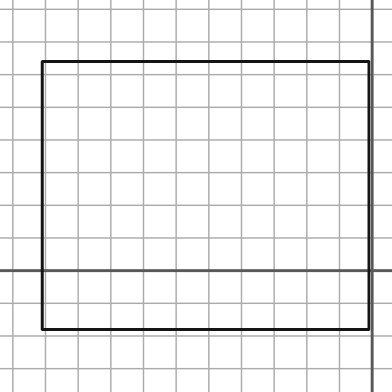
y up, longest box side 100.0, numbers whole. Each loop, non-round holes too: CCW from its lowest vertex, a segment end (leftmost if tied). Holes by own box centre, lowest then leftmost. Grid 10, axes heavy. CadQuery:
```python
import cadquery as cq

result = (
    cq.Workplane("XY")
    .moveTo(-101.0, -18.0)
    .lineTo(-1.0, -18.0)
    .lineTo(-1.0, 64.0)
    .lineTo(-101.0, 64.0)
    .close()
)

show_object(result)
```